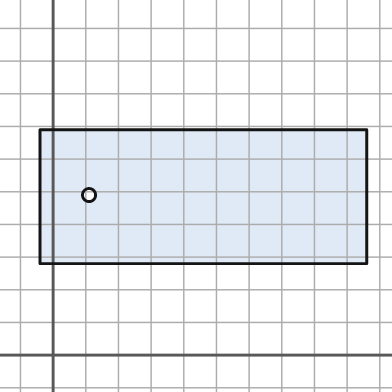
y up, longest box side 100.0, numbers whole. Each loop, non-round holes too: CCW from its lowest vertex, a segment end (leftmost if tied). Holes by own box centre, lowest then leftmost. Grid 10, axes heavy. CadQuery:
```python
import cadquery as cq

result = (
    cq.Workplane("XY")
    .moveTo(-4.0, 28.0)
    .lineTo(96.0, 28.0)
    .lineTo(96.0, 69.0)
    .lineTo(-4.0, 69.0)
    .close()
    .moveTo(11.0, 49.0)
    .circle(2.0)
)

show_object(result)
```